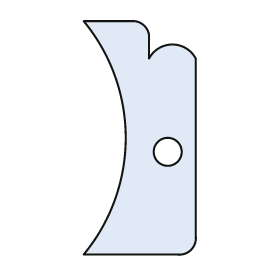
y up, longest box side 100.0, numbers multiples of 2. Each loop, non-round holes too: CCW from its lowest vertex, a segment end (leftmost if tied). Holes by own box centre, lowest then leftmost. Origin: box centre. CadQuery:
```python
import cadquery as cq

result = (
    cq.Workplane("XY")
    .moveTo(-24.0, -50.0)
    .lineTo(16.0, -50.0)
    .threePointArc((22.0, -48.0), (24.0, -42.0))
    .lineTo(24.0, 34.0)
    .threePointArc((14.0, 40.0), (4.0, 34.0))
    .lineTo(4.0, 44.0)
    .threePointArc((2.0, 48.0), (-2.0, 50.0))
    .lineTo(-24.0, 50.0)
    .threePointArc((-6.0, 0.0), (-24.0, -50.0))
    .close()
    .moveTo(12.0, -6.0)
    .circle(6.0)
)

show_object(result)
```